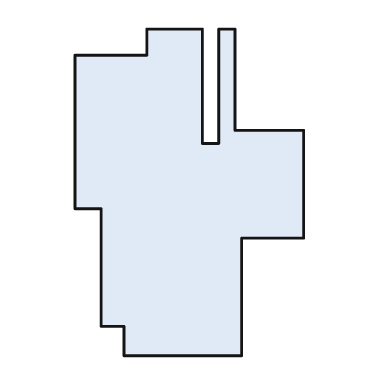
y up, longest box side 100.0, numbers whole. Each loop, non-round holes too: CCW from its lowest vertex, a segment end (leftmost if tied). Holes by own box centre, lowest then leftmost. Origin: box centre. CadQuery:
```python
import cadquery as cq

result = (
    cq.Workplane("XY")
    .moveTo(-20.0, -50.0)
    .lineTo(16.0, -50.0)
    .lineTo(16.0, -14.0)
    .lineTo(35.0, -14.0)
    .lineTo(35.0, 19.0)
    .lineTo(14.0, 19.0)
    .lineTo(14.0, 50.0)
    .lineTo(9.0, 50.0)
    .lineTo(9.0, 15.0)
    .lineTo(4.0, 15.0)
    .lineTo(4.0, 50.0)
    .lineTo(-13.0, 50.0)
    .lineTo(-13.0, 42.0)
    .lineTo(-35.0, 42.0)
    .lineTo(-35.0, -5.0)
    .lineTo(-27.0, -5.0)
    .lineTo(-27.0, -41.0)
    .lineTo(-20.0, -41.0)
    .close()
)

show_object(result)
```